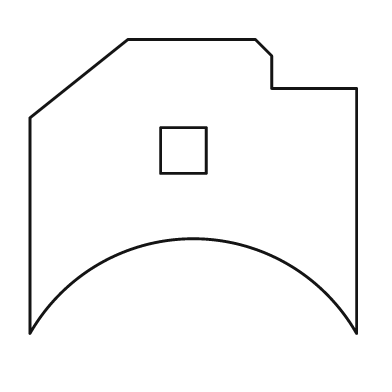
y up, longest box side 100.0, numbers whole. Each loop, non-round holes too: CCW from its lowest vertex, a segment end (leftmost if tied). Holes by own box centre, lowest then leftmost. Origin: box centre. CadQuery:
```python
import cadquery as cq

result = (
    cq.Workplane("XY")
    .moveTo(-50.0, -45.0)
    .threePointArc((0.0, -16.0), (50.0, -45.0))
    .lineTo(50.0, 30.0)
    .lineTo(24.0, 30.0)
    .lineTo(24.0, 40.0)
    .lineTo(19.0, 45.0)
    .lineTo(-20.0, 45.0)
    .lineTo(-50.0, 21.0)
    .close()
    .moveTo(-10.0, 4.0)
    .lineTo(4.0, 4.0)
    .lineTo(4.0, 18.0)
    .lineTo(-10.0, 18.0)
    .close()
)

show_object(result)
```